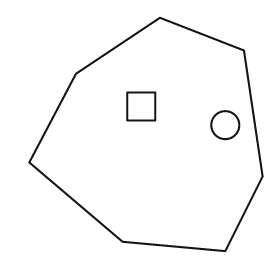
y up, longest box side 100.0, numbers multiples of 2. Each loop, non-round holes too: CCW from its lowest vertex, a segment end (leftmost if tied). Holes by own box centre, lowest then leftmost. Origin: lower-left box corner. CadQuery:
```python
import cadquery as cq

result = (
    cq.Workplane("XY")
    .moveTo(84.0, 0.0)
    .lineTo(100.0, 32.0)
    .lineTo(92.0, 86.0)
    .lineTo(56.0, 100.0)
    .lineTo(20.0, 76.0)
    .lineTo(0.0, 38.0)
    .lineTo(40.0, 4.0)
    .close()
    .moveTo(84.0, 54.0)
    .circle(6.0)
    .moveTo(42.0, 56.0)
    .lineTo(54.0, 56.0)
    .lineTo(54.0, 68.0)
    .lineTo(42.0, 68.0)
    .close()
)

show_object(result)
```